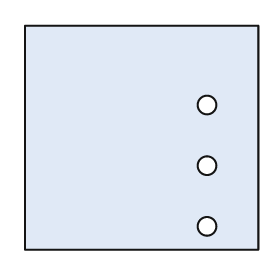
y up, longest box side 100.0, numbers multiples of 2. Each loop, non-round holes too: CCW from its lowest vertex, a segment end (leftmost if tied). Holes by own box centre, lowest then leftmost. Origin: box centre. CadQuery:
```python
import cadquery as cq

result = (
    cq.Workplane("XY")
    .moveTo(-50.0, -48.0)
    .lineTo(50.0, -48.0)
    .lineTo(50.0, 48.0)
    .lineTo(-50.0, 48.0)
    .close()
    .moveTo(28.0, -38.0)
    .circle(4.0)
    .moveTo(28.0, -12.0)
    .circle(4.0)
    .moveTo(28.0, 14.0)
    .circle(4.0)
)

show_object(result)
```